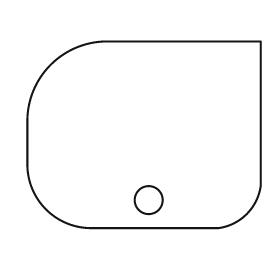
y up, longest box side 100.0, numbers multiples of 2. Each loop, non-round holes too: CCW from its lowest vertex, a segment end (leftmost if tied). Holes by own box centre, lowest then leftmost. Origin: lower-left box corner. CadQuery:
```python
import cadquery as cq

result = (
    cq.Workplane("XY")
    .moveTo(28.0, 0.0)
    .lineTo(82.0, 0.0)
    .threePointArc((94.0, 6.0), (100.0, 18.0))
    .lineTo(100.0, 80.0)
    .lineTo(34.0, 80.0)
    .threePointArc((10.0, 70.0), (0.0, 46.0))
    .lineTo(0.0, 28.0)
    .threePointArc((8.0, 8.0), (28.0, 0.0))
    .close()
    .moveTo(52.0, 12.0)
    .circle(6.0)
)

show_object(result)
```